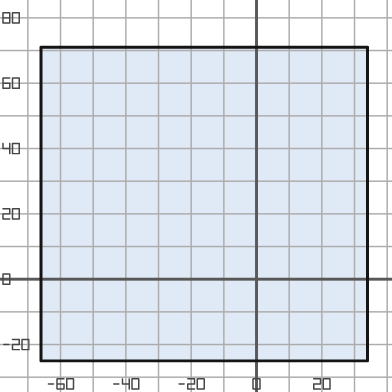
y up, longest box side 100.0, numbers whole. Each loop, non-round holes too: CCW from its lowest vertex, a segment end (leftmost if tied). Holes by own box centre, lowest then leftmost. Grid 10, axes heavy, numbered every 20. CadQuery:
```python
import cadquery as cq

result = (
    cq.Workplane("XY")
    .moveTo(-66.0, -25.0)
    .lineTo(34.0, -25.0)
    .lineTo(34.0, 71.0)
    .lineTo(-66.0, 71.0)
    .close()
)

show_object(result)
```